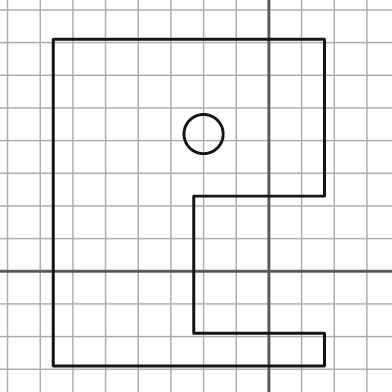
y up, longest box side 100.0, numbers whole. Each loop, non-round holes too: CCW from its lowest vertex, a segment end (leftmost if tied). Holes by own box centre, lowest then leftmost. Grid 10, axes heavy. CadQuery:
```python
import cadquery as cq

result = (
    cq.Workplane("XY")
    .moveTo(-66.0, -29.0)
    .lineTo(17.0, -29.0)
    .lineTo(17.0, -19.0)
    .lineTo(-23.0, -19.0)
    .lineTo(-23.0, 23.0)
    .lineTo(17.0, 23.0)
    .lineTo(17.0, 71.0)
    .lineTo(-66.0, 71.0)
    .close()
    .moveTo(-20.0, 42.0)
    .circle(6.0)
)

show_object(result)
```